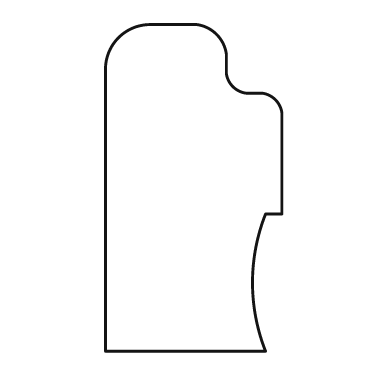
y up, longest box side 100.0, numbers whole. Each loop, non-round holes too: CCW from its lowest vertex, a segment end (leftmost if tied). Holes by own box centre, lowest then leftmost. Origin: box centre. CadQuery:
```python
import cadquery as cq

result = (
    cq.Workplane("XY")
    .moveTo(-27.0, -50.0)
    .lineTo(22.0, -50.0)
    .threePointArc((18.0, -29.0), (22.0, -8.0))
    .lineTo(27.0, -8.0)
    .lineTo(27.0, 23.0)
    .threePointArc((25.0, 27.0), (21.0, 29.0))
    .lineTo(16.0, 29.0)
    .threePointArc((12.0, 31.0), (10.0, 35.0))
    .lineTo(10.0, 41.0)
    .threePointArc((7.0, 47.0), (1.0, 50.0))
    .lineTo(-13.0, 50.0)
    .threePointArc((-23.0, 46.0), (-27.0, 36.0))
    .close()
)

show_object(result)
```